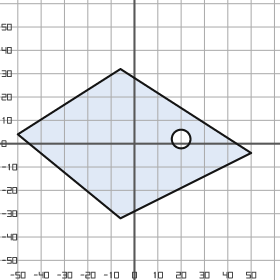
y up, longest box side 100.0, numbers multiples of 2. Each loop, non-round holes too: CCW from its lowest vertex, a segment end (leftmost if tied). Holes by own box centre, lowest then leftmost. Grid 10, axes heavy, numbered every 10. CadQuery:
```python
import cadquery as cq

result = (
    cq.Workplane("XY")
    .moveTo(-6.0, -32.0)
    .lineTo(50.0, -4.0)
    .lineTo(-6.0, 32.0)
    .lineTo(-50.0, 4.0)
    .close()
    .moveTo(20.0, 2.0)
    .circle(4.0)
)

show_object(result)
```